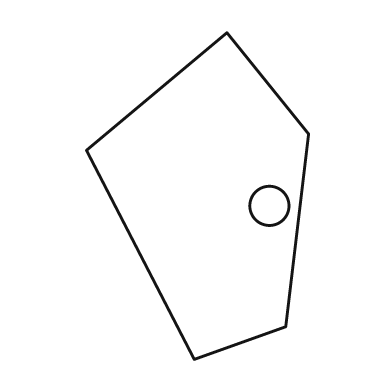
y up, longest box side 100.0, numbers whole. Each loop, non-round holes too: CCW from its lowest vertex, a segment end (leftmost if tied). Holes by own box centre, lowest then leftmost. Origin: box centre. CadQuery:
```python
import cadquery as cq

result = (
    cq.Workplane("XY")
    .moveTo(-1.0, -50.0)
    .lineTo(27.0, -40.0)
    .lineTo(34.0, 19.0)
    .lineTo(9.0, 50.0)
    .lineTo(-34.0, 14.0)
    .close()
    .moveTo(22.0, -3.0)
    .circle(6.0)
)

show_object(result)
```